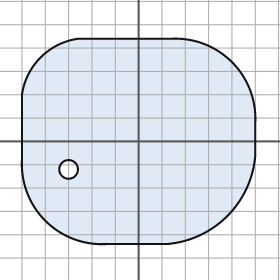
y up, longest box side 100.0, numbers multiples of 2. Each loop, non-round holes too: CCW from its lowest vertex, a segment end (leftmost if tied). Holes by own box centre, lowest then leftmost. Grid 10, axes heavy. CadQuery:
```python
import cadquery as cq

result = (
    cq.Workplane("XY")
    .moveTo(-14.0, -44.0)
    .lineTo(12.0, -44.0)
    .threePointArc((38.0, -32.0), (50.0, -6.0))
    .lineTo(50.0, 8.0)
    .threePointArc((40.0, 34.0), (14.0, 44.0))
    .lineTo(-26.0, 44.0)
    .threePointArc((-42.0, 36.0), (-50.0, 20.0))
    .lineTo(-50.0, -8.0)
    .threePointArc((-40.0, -34.0), (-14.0, -44.0))
    .close()
    .moveTo(-30.0, -12.0)
    .circle(4.0)
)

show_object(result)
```